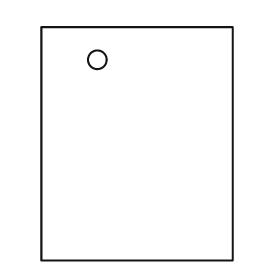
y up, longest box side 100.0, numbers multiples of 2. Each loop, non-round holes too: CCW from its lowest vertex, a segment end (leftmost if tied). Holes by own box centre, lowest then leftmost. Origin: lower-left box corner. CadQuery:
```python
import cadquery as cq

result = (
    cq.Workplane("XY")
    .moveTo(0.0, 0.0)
    .lineTo(82.0, 0.0)
    .lineTo(82.0, 100.0)
    .lineTo(0.0, 100.0)
    .close()
    .moveTo(24.0, 86.0)
    .circle(4.0)
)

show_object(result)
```